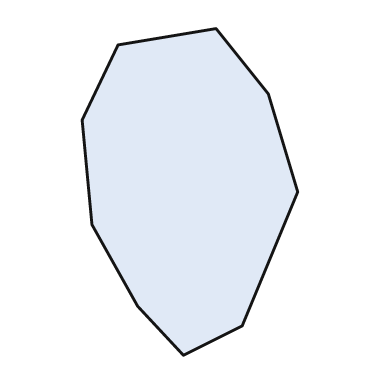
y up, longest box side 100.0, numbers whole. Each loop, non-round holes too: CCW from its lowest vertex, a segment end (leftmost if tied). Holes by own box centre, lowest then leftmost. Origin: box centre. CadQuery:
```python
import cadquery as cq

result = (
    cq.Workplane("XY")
    .moveTo(-2.0, -50.0)
    .lineTo(16.0, -41.0)
    .lineTo(33.0, 0.0)
    .lineTo(24.0, 30.0)
    .lineTo(8.0, 50.0)
    .lineTo(-22.0, 45.0)
    .lineTo(-33.0, 22.0)
    .lineTo(-30.0, -10.0)
    .lineTo(-16.0, -35.0)
    .close()
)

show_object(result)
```